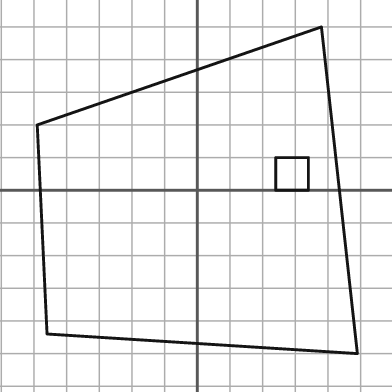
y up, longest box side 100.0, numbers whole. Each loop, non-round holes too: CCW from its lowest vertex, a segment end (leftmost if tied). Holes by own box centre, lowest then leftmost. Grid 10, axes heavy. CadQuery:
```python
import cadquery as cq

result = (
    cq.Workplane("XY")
    .moveTo(49.0, -50.0)
    .lineTo(38.0, 50.0)
    .lineTo(-49.0, 20.0)
    .lineTo(-46.0, -44.0)
    .close()
    .moveTo(24.0, 0.0)
    .lineTo(34.0, 0.0)
    .lineTo(34.0, 10.0)
    .lineTo(24.0, 10.0)
    .close()
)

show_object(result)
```